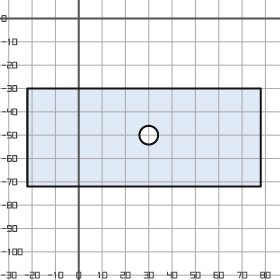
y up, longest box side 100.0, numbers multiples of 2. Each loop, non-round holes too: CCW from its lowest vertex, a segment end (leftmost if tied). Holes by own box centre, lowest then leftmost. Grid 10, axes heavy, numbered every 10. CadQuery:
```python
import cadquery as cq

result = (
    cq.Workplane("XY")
    .moveTo(-22.0, -72.0)
    .lineTo(78.0, -72.0)
    .lineTo(78.0, -30.0)
    .lineTo(-22.0, -30.0)
    .close()
    .moveTo(30.0, -50.0)
    .circle(4.0)
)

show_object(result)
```